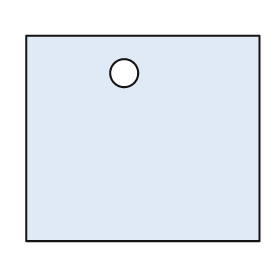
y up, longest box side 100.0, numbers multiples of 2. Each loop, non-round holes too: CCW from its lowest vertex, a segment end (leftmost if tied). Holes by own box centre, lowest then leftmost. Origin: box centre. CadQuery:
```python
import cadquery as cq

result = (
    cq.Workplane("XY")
    .moveTo(-50.0, -44.0)
    .lineTo(50.0, -44.0)
    .lineTo(50.0, 44.0)
    .lineTo(-50.0, 44.0)
    .close()
    .moveTo(-8.0, 28.0)
    .circle(6.0)
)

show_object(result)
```